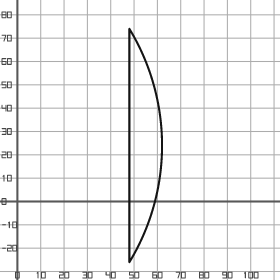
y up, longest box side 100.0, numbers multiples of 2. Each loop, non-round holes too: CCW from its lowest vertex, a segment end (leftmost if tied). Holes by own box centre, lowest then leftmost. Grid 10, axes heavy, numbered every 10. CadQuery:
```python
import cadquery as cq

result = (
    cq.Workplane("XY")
    .moveTo(48.0, -26.0)
    .threePointArc((62.0, 24.0), (48.0, 74.0))
    .close()
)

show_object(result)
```